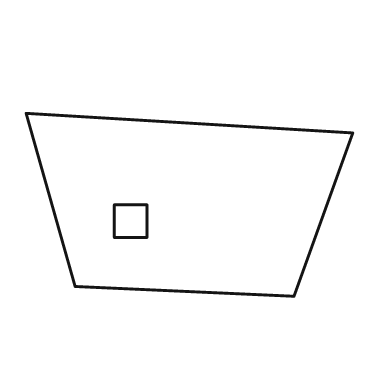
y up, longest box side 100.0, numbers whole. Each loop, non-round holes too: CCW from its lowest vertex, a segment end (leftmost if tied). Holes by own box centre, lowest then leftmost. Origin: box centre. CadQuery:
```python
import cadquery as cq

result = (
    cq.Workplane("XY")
    .moveTo(32.0, -28.0)
    .lineTo(50.0, 22.0)
    .lineTo(-50.0, 28.0)
    .lineTo(-35.0, -25.0)
    .close()
    .moveTo(-23.0, -10.0)
    .lineTo(-13.0, -10.0)
    .lineTo(-13.0, 0.0)
    .lineTo(-23.0, 0.0)
    .close()
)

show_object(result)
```